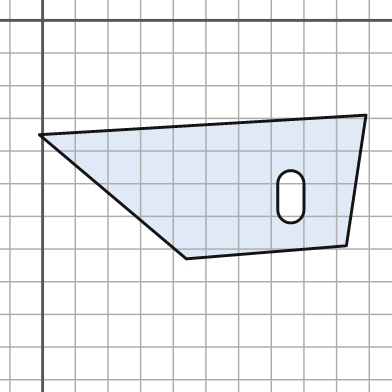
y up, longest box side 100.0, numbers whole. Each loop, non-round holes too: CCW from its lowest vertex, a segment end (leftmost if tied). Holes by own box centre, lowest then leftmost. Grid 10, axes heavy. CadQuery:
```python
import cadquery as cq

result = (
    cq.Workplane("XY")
    .moveTo(44.0, -73.0)
    .lineTo(93.0, -69.0)
    .lineTo(99.0, -29.0)
    .lineTo(-1.0, -35.0)
    .close()
    .moveTo(72.0, -58.0)
    .threePointArc((76.0, -62.0), (80.0, -58.0))
    .lineTo(80.0, -50.0)
    .threePointArc((76.0, -46.0), (72.0, -50.0))
    .close()
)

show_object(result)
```